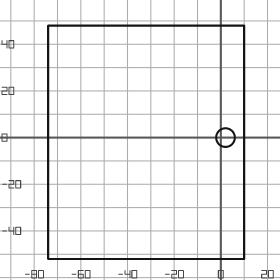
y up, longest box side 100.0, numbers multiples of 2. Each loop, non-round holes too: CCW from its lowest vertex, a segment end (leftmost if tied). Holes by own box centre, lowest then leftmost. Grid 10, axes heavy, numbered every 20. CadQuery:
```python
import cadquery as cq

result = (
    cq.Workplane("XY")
    .moveTo(-74.0, -52.0)
    .lineTo(10.0, -52.0)
    .lineTo(10.0, 48.0)
    .lineTo(-74.0, 48.0)
    .close()
    .moveTo(2.0, 0.0)
    .circle(4.0)
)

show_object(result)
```